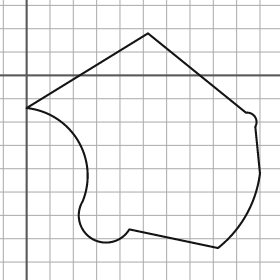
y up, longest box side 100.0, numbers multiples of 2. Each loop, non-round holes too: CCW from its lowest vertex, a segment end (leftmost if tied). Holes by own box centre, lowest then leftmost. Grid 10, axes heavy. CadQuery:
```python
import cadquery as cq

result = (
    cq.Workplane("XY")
    .moveTo(82.0, -74.0)
    .threePointArc((94.0, -60.0), (100.0, -42.0))
    .lineTo(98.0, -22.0)
    .threePointArc((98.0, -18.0), (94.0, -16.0))
    .lineTo(52.0, 18.0)
    .lineTo(0.0, -14.0)
    .threePointArc((22.0, -28.0), (24.0, -54.0))
    .threePointArc((28.0, -70.0), (44.0, -66.0))
    .close()
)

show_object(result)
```